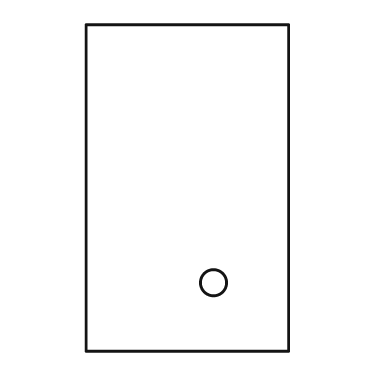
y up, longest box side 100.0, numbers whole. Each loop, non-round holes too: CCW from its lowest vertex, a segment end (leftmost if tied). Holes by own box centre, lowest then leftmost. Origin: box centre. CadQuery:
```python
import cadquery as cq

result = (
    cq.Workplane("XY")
    .moveTo(-31.0, -50.0)
    .lineTo(31.0, -50.0)
    .lineTo(31.0, 50.0)
    .lineTo(-31.0, 50.0)
    .close()
    .moveTo(8.0, -29.0)
    .circle(4.0)
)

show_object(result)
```